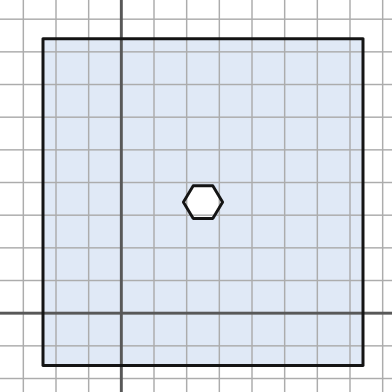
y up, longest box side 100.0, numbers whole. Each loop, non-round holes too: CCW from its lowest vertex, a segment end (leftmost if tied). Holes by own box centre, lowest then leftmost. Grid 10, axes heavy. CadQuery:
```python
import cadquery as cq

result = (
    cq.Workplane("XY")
    .moveTo(-24.0, -16.0)
    .lineTo(74.0, -16.0)
    .lineTo(74.0, 84.0)
    .lineTo(-24.0, 84.0)
    .close()
    .moveTo(22.0, 29.0)
    .lineTo(28.0, 29.0)
    .lineTo(31.0, 34.0)
    .lineTo(28.0, 39.0)
    .lineTo(22.0, 39.0)
    .lineTo(19.0, 34.0)
    .close()
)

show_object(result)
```